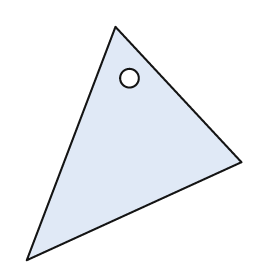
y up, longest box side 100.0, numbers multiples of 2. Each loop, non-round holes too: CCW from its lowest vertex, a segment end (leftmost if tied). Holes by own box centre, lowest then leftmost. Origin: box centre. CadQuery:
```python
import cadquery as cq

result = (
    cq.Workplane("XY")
    .moveTo(-46.0, -50.0)
    .lineTo(46.0, -8.0)
    .lineTo(-8.0, 50.0)
    .close()
    .moveTo(-2.0, 28.0)
    .circle(4.0)
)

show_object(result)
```